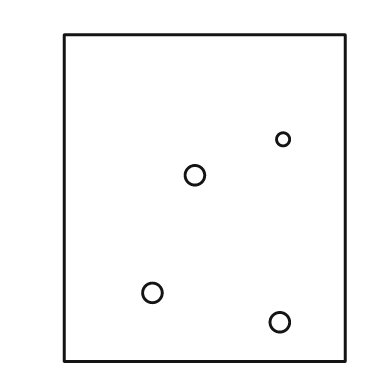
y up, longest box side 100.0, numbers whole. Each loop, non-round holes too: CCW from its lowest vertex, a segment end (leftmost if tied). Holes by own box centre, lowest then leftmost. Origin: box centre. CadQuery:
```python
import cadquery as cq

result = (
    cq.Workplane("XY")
    .moveTo(-43.0, -50.0)
    .lineTo(43.0, -50.0)
    .lineTo(43.0, 50.0)
    .lineTo(-43.0, 50.0)
    .close()
    .moveTo(23.0, -38.0)
    .circle(3.0)
    .moveTo(-16.0, -29.0)
    .circle(3.0)
    .moveTo(-3.0, 7.0)
    .circle(3.0)
    .moveTo(24.0, 18.0)
    .circle(2.0)
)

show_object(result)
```